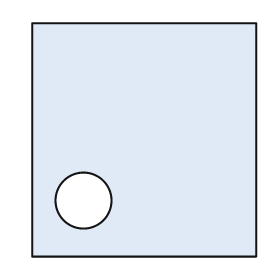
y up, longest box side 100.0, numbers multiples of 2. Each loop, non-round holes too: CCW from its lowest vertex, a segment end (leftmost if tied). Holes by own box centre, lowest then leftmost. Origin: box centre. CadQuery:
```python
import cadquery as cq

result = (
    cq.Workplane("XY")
    .moveTo(-48.0, -50.0)
    .lineTo(48.0, -50.0)
    .lineTo(48.0, 50.0)
    .lineTo(-48.0, 50.0)
    .close()
    .moveTo(-26.0, -26.0)
    .circle(12.0)
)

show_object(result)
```